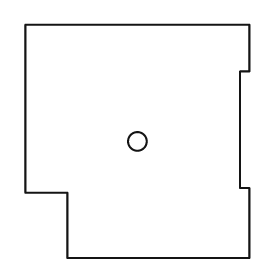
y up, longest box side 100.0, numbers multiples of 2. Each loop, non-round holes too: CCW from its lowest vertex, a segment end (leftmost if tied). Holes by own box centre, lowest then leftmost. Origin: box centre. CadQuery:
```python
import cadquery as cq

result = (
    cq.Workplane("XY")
    .moveTo(-30.0, -50.0)
    .lineTo(48.0, -50.0)
    .lineTo(48.0, -20.0)
    .lineTo(44.0, -20.0)
    .lineTo(44.0, 30.0)
    .lineTo(48.0, 30.0)
    .lineTo(48.0, 50.0)
    .lineTo(-48.0, 50.0)
    .lineTo(-48.0, -22.0)
    .lineTo(-30.0, -22.0)
    .close()
    .moveTo(0.0, 0.0)
    .circle(4.0)
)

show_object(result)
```